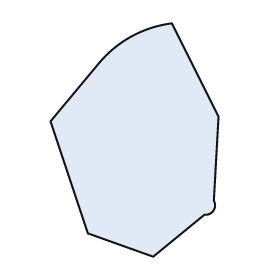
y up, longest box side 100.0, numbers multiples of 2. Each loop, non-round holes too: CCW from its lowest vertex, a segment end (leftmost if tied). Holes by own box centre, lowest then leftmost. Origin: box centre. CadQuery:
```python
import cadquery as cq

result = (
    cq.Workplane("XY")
    .moveTo(8.0, -50.0)
    .lineTo(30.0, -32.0)
    .threePointArc((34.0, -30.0), (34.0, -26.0))
    .lineTo(36.0, 10.0)
    .lineTo(16.0, 50.0)
    .threePointArc((-2.0, 44.0), (-16.0, 32.0))
    .lineTo(-36.0, 8.0)
    .lineTo(-20.0, -40.0)
    .close()
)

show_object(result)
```